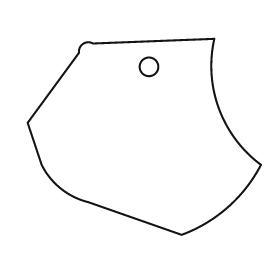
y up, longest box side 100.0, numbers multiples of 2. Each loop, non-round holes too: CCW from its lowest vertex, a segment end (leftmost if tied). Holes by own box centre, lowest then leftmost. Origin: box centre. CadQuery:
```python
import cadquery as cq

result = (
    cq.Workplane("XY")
    .moveTo(16.0, -42.0)
    .threePointArc((36.0, -30.0), (50.0, -12.0))
    .threePointArc((32.0, 12.0), (30.0, 42.0))
    .lineTo(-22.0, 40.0)
    .threePointArc((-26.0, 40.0), (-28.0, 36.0))
    .lineTo(-50.0, 6.0)
    .lineTo(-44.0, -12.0)
    .threePointArc((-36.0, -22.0), (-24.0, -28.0))
    .close()
    .moveTo(2.0, 30.0)
    .circle(4.0)
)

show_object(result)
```